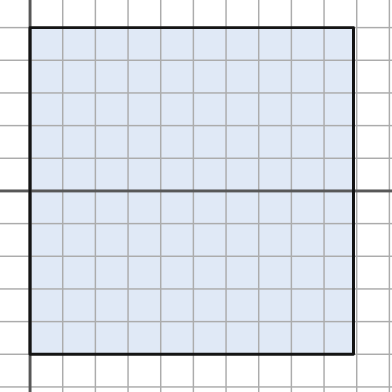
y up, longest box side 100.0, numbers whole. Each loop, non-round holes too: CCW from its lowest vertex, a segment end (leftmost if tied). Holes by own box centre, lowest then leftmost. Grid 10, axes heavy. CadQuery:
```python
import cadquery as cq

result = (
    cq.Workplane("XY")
    .moveTo(0.0, -50.0)
    .lineTo(99.0, -50.0)
    .lineTo(99.0, 50.0)
    .lineTo(0.0, 50.0)
    .close()
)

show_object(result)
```